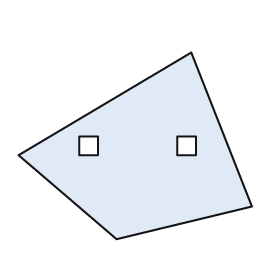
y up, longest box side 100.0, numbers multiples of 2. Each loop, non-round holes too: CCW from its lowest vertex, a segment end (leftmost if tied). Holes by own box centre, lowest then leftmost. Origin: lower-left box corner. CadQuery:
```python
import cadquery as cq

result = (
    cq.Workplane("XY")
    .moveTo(42.0, 0.0)
    .lineTo(100.0, 14.0)
    .lineTo(74.0, 80.0)
    .lineTo(0.0, 36.0)
    .close()
    .moveTo(26.0, 36.0)
    .lineTo(34.0, 36.0)
    .lineTo(34.0, 44.0)
    .lineTo(26.0, 44.0)
    .close()
    .moveTo(68.0, 36.0)
    .lineTo(76.0, 36.0)
    .lineTo(76.0, 44.0)
    .lineTo(68.0, 44.0)
    .close()
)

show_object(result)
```